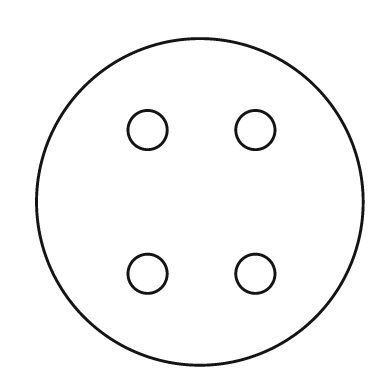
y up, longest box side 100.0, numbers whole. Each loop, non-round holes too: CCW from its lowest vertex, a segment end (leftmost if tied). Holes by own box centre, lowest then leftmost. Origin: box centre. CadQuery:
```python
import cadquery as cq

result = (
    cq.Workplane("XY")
    .moveTo(0.0, 0.0)
    .circle(50.0)
    .moveTo(-16.0, -22.0)
    .circle(6.0)
    .moveTo(17.0, -22.0)
    .circle(6.0)
    .moveTo(-16.0, 22.0)
    .circle(6.0)
    .moveTo(17.0, 22.0)
    .circle(6.0)
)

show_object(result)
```